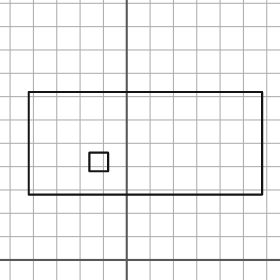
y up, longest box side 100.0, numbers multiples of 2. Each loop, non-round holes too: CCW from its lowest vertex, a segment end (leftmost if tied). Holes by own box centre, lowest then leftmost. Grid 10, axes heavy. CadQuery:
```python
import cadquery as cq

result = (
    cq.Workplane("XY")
    .moveTo(-42.0, 28.0)
    .lineTo(58.0, 28.0)
    .lineTo(58.0, 72.0)
    .lineTo(-42.0, 72.0)
    .close()
    .moveTo(-16.0, 38.0)
    .lineTo(-8.0, 38.0)
    .lineTo(-8.0, 46.0)
    .lineTo(-16.0, 46.0)
    .close()
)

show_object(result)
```